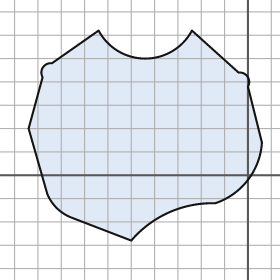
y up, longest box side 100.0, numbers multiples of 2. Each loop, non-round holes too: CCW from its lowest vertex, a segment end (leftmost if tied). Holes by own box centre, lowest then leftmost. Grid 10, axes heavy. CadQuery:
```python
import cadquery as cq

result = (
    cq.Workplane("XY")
    .moveTo(-50.0, -28.0)
    .threePointArc((-34.0, -16.0), (-14.0, -12.0))
    .threePointArc((0.0, -2.0), (6.0, 14.0))
    .lineTo(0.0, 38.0)
    .threePointArc((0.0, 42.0), (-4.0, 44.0))
    .lineTo(-24.0, 62.0)
    .threePointArc((-44.0, 50.0), (-64.0, 62.0))
    .lineTo(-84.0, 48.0)
    .threePointArc((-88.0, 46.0), (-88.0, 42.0))
    .lineTo(-94.0, 20.0)
    .lineTo(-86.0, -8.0)
    .threePointArc((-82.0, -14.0), (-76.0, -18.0))
    .close()
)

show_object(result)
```